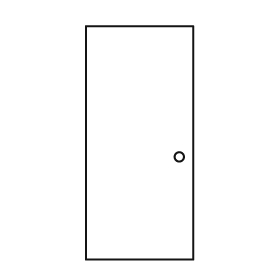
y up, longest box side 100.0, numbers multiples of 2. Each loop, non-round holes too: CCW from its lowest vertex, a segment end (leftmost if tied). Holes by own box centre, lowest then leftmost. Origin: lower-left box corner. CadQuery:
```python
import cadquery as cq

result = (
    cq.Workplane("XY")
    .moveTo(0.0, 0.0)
    .lineTo(46.0, 0.0)
    .lineTo(46.0, 100.0)
    .lineTo(0.0, 100.0)
    .close()
    .moveTo(40.0, 44.0)
    .circle(2.0)
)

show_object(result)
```